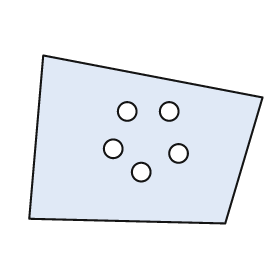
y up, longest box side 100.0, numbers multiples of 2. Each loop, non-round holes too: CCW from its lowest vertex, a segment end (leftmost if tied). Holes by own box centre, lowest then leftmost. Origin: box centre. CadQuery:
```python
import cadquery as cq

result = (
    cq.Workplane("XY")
    .moveTo(34.0, -36.0)
    .lineTo(50.0, 18.0)
    .lineTo(-44.0, 36.0)
    .lineTo(-50.0, -34.0)
    .close()
    .moveTo(-2.0, -14.0)
    .circle(4.0)
    .moveTo(14.0, -6.0)
    .circle(4.0)
    .moveTo(-14.0, -4.0)
    .circle(4.0)
    .moveTo(-8.0, 12.0)
    .circle(4.0)
    .moveTo(10.0, 12.0)
    .circle(4.0)
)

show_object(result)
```